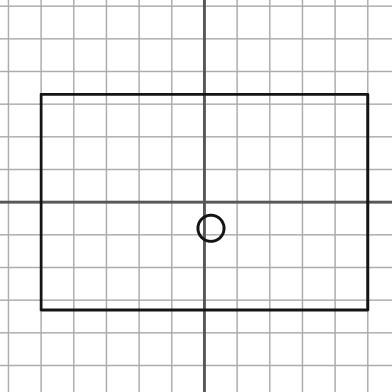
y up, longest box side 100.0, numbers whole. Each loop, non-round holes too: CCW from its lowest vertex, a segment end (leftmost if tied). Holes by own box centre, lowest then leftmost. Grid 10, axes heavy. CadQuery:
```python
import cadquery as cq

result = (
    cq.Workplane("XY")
    .moveTo(-50.0, -33.0)
    .lineTo(50.0, -33.0)
    .lineTo(50.0, 33.0)
    .lineTo(-50.0, 33.0)
    .close()
    .moveTo(2.0, -8.0)
    .circle(4.0)
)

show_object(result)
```